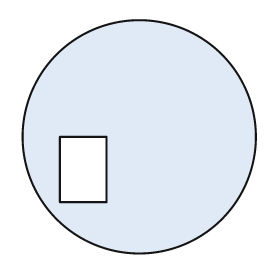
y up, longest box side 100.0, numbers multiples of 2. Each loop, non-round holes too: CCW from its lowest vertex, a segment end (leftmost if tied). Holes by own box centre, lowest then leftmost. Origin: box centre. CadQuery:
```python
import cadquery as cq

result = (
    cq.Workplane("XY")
    .moveTo(0.0, 0.0)
    .circle(50.0)
    .moveTo(-34.0, -28.0)
    .lineTo(-14.0, -28.0)
    .lineTo(-14.0, 0.0)
    .lineTo(-34.0, 0.0)
    .close()
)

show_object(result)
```